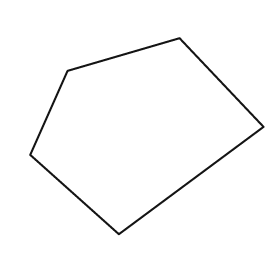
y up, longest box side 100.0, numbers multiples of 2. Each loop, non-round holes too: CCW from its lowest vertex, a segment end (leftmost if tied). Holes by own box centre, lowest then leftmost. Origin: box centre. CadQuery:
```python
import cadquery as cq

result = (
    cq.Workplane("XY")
    .moveTo(-12.0, -42.0)
    .lineTo(50.0, 4.0)
    .lineTo(14.0, 42.0)
    .lineTo(-34.0, 28.0)
    .lineTo(-50.0, -8.0)
    .close()
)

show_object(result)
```